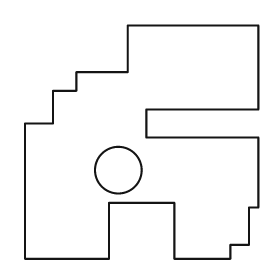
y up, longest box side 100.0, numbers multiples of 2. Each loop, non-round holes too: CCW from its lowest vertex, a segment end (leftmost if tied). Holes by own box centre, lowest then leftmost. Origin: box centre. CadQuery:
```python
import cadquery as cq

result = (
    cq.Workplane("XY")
    .moveTo(-50.0, -50.0)
    .lineTo(-14.0, -50.0)
    .lineTo(-14.0, -26.0)
    .lineTo(14.0, -26.0)
    .lineTo(14.0, -50.0)
    .lineTo(38.0, -50.0)
    .lineTo(38.0, -44.0)
    .lineTo(46.0, -44.0)
    .lineTo(46.0, -28.0)
    .lineTo(50.0, -28.0)
    .lineTo(50.0, 2.0)
    .lineTo(2.0, 2.0)
    .lineTo(2.0, 14.0)
    .lineTo(50.0, 14.0)
    .lineTo(50.0, 50.0)
    .lineTo(-6.0, 50.0)
    .lineTo(-6.0, 30.0)
    .lineTo(-28.0, 30.0)
    .lineTo(-28.0, 22.0)
    .lineTo(-38.0, 22.0)
    .lineTo(-38.0, 8.0)
    .lineTo(-50.0, 8.0)
    .close()
    .moveTo(-10.0, -12.0)
    .circle(10.0)
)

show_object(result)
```